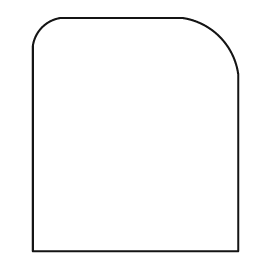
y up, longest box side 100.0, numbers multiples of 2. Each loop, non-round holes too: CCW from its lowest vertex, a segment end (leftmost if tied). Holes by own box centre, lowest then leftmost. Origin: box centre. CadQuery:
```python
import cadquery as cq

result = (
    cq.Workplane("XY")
    .moveTo(-44.0, -50.0)
    .lineTo(44.0, -50.0)
    .lineTo(44.0, 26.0)
    .threePointArc((36.0, 42.0), (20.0, 50.0))
    .lineTo(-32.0, 50.0)
    .threePointArc((-40.0, 46.0), (-44.0, 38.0))
    .close()
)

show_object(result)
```